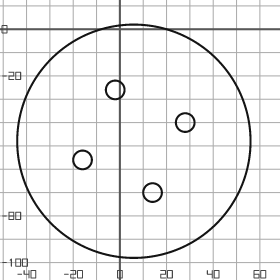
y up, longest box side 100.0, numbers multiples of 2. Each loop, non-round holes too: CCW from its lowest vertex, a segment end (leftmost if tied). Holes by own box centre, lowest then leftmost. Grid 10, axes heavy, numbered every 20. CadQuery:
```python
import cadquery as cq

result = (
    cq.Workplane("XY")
    .moveTo(6.0, -48.0)
    .circle(50.0)
    .moveTo(14.0, -70.0)
    .circle(4.0)
    .moveTo(-16.0, -56.0)
    .circle(4.0)
    .moveTo(28.0, -40.0)
    .circle(4.0)
    .moveTo(-2.0, -26.0)
    .circle(4.0)
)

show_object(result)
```